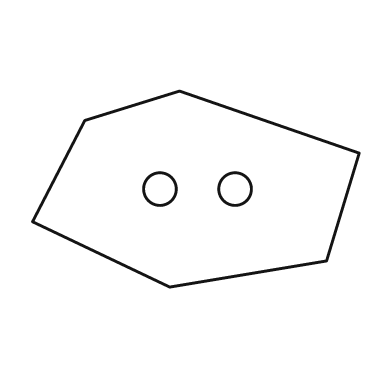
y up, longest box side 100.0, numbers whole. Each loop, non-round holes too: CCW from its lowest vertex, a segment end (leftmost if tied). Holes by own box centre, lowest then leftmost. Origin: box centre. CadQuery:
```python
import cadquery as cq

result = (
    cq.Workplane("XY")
    .moveTo(-8.0, -30.0)
    .lineTo(40.0, -22.0)
    .lineTo(50.0, 11.0)
    .lineTo(-5.0, 30.0)
    .lineTo(-34.0, 21.0)
    .lineTo(-50.0, -10.0)
    .close()
    .moveTo(-11.0, 0.0)
    .circle(5.0)
    .moveTo(12.0, 0.0)
    .circle(5.0)
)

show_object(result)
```